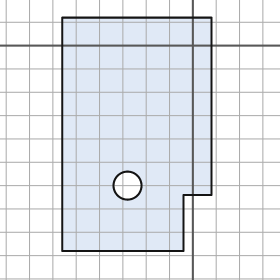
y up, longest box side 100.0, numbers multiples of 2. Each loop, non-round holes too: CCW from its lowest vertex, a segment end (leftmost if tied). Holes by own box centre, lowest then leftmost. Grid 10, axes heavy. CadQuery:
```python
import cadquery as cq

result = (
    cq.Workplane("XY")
    .moveTo(-56.0, -88.0)
    .lineTo(-4.0, -88.0)
    .lineTo(-4.0, -64.0)
    .lineTo(8.0, -64.0)
    .lineTo(8.0, 12.0)
    .lineTo(-56.0, 12.0)
    .close()
    .moveTo(-28.0, -60.0)
    .circle(6.0)
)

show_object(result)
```